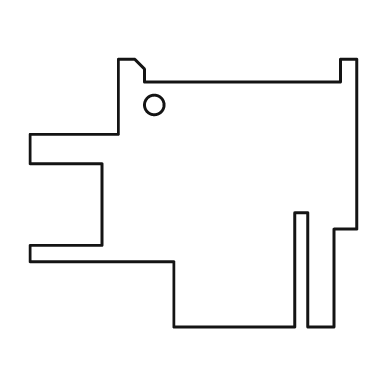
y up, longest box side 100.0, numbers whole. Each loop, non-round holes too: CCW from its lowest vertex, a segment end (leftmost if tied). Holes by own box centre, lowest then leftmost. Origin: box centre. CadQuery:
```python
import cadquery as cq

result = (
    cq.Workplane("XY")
    .moveTo(-6.0, -41.0)
    .lineTo(31.0, -41.0)
    .lineTo(31.0, -6.0)
    .lineTo(35.0, -6.0)
    .lineTo(35.0, -41.0)
    .lineTo(43.0, -41.0)
    .lineTo(43.0, -11.0)
    .lineTo(50.0, -11.0)
    .lineTo(50.0, 41.0)
    .lineTo(45.0, 41.0)
    .lineTo(45.0, 34.0)
    .lineTo(-15.0, 34.0)
    .lineTo(-15.0, 38.0)
    .lineTo(-18.0, 41.0)
    .lineTo(-23.0, 41.0)
    .lineTo(-23.0, 18.0)
    .lineTo(-50.0, 18.0)
    .lineTo(-50.0, 9.0)
    .lineTo(-28.0, 9.0)
    .lineTo(-28.0, -16.0)
    .lineTo(-50.0, -16.0)
    .lineTo(-50.0, -21.0)
    .lineTo(-6.0, -21.0)
    .close()
    .moveTo(-12.0, 27.0)
    .circle(3.0)
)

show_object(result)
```